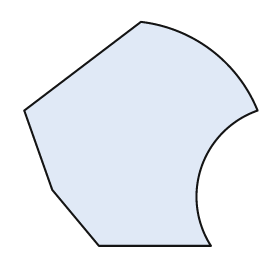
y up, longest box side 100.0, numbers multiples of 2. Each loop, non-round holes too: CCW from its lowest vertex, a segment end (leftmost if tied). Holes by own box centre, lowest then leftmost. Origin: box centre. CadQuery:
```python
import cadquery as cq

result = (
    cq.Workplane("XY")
    .moveTo(-18.0, -48.0)
    .lineTo(30.0, -48.0)
    .threePointArc((26.0, -14.0), (50.0, 10.0))
    .threePointArc((30.0, 36.0), (0.0, 48.0))
    .lineTo(-50.0, 10.0)
    .lineTo(-38.0, -24.0)
    .close()
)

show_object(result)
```